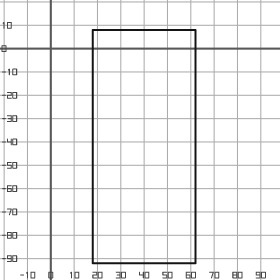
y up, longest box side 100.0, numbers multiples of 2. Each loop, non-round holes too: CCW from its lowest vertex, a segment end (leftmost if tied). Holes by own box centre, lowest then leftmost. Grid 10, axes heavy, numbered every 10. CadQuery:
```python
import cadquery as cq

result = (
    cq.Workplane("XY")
    .moveTo(18.0, -92.0)
    .lineTo(62.0, -92.0)
    .lineTo(62.0, 8.0)
    .lineTo(18.0, 8.0)
    .close()
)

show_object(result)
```